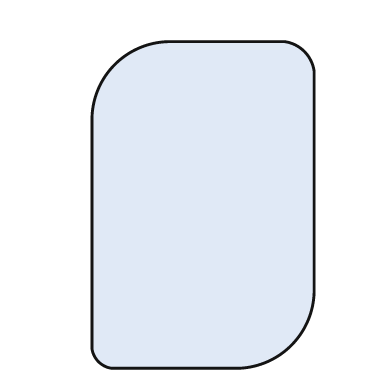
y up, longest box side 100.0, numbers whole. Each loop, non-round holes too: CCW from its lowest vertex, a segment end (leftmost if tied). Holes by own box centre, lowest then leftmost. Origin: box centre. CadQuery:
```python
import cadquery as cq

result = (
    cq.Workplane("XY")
    .moveTo(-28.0, -50.0)
    .lineTo(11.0, -50.0)
    .threePointArc((27.0, -43.0), (34.0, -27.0))
    .lineTo(34.0, 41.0)
    .threePointArc((31.0, 47.0), (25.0, 50.0))
    .lineTo(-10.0, 50.0)
    .threePointArc((-27.0, 43.0), (-34.0, 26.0))
    .lineTo(-34.0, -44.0)
    .threePointArc((-32.0, -48.0), (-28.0, -50.0))
    .close()
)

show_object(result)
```